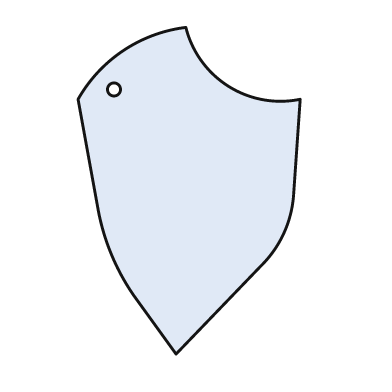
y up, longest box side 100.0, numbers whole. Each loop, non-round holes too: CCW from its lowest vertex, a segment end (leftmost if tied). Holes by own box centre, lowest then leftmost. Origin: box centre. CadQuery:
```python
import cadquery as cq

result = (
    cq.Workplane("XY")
    .moveTo(-4.0, -50.0)
    .lineTo(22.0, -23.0)
    .threePointArc((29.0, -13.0), (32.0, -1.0))
    .lineTo(34.0, 28.0)
    .threePointArc((12.0, 32.0), (-1.0, 50.0))
    .threePointArc((-20.0, 43.0), (-34.0, 28.0))
    .lineTo(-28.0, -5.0)
    .threePointArc((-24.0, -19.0), (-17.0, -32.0))
    .close()
    .moveTo(-23.0, 31.0)
    .circle(2.0)
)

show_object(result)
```